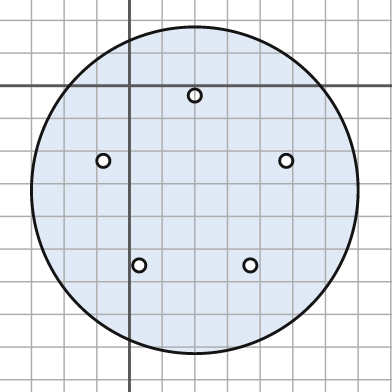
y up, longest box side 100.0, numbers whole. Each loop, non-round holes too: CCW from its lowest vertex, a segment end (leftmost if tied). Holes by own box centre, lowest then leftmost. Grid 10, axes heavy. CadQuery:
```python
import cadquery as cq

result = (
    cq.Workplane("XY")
    .moveTo(20.0, -32.0)
    .circle(50.0)
    .moveTo(3.0, -55.0)
    .circle(2.0)
    .moveTo(37.0, -55.0)
    .circle(2.0)
    .moveTo(-8.0, -23.0)
    .circle(2.0)
    .moveTo(48.0, -23.0)
    .circle(2.0)
    .moveTo(20.0, -3.0)
    .circle(2.0)
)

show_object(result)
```